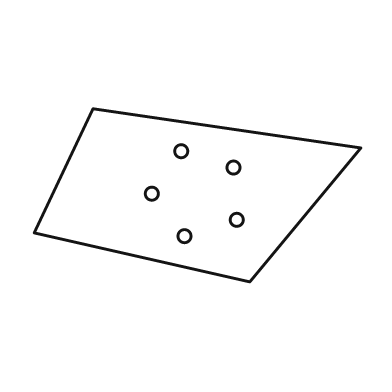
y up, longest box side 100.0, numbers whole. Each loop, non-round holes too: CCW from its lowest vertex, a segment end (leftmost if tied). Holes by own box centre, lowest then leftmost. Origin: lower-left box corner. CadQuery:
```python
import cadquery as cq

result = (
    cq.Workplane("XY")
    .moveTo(66.0, 0.0)
    .lineTo(100.0, 41.0)
    .lineTo(18.0, 53.0)
    .lineTo(0.0, 15.0)
    .close()
    .moveTo(46.0, 14.0)
    .circle(2.0)
    .moveTo(62.0, 19.0)
    .circle(2.0)
    .moveTo(36.0, 27.0)
    .circle(2.0)
    .moveTo(61.0, 35.0)
    .circle(2.0)
    .moveTo(45.0, 40.0)
    .circle(2.0)
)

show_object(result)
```